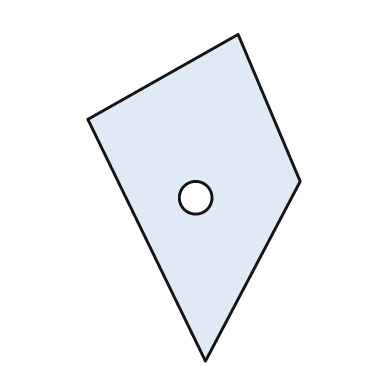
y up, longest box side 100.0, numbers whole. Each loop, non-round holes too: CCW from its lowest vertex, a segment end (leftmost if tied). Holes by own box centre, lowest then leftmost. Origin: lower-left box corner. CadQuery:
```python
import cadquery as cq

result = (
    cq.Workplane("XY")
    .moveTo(36.0, 0.0)
    .lineTo(65.0, 55.0)
    .lineTo(46.0, 100.0)
    .lineTo(0.0, 74.0)
    .close()
    .moveTo(33.0, 50.0)
    .circle(5.0)
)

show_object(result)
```